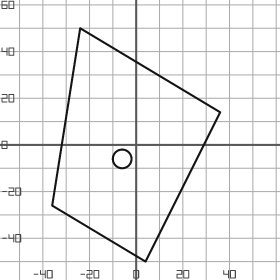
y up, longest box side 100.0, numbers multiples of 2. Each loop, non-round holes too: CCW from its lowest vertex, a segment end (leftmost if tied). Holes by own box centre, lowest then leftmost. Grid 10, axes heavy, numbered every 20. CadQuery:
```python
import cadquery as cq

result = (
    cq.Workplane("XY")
    .moveTo(4.0, -50.0)
    .lineTo(36.0, 14.0)
    .lineTo(-24.0, 50.0)
    .lineTo(-36.0, -26.0)
    .close()
    .moveTo(-6.0, -6.0)
    .circle(4.0)
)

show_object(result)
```